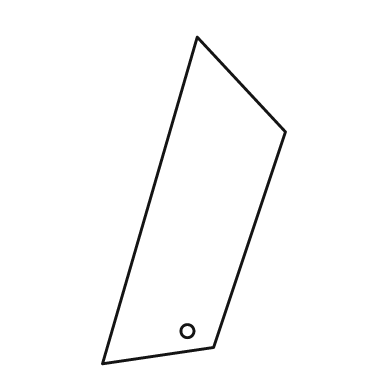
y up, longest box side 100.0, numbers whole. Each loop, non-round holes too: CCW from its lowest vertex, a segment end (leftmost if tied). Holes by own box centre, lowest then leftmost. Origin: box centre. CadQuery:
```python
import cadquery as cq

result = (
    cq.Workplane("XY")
    .moveTo(-28.0, -50.0)
    .lineTo(6.0, -45.0)
    .lineTo(28.0, 21.0)
    .lineTo(1.0, 50.0)
    .close()
    .moveTo(-2.0, -40.0)
    .circle(2.0)
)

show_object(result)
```